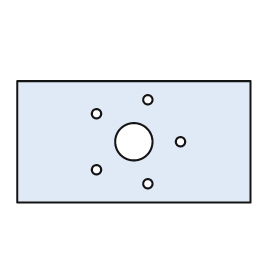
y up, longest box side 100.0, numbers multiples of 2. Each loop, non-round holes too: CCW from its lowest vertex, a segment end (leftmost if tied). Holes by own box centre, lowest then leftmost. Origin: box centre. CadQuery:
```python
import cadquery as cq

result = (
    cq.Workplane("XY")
    .moveTo(-50.0, -26.0)
    .lineTo(50.0, -26.0)
    .lineTo(50.0, 26.0)
    .lineTo(-50.0, 26.0)
    .close()
    .moveTo(6.0, -18.0)
    .circle(2.0)
    .moveTo(-16.0, -12.0)
    .circle(2.0)
    .moveTo(0.0, 0.0)
    .circle(8.0)
    .moveTo(20.0, 0.0)
    .circle(2.0)
    .moveTo(-16.0, 12.0)
    .circle(2.0)
    .moveTo(6.0, 18.0)
    .circle(2.0)
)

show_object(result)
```